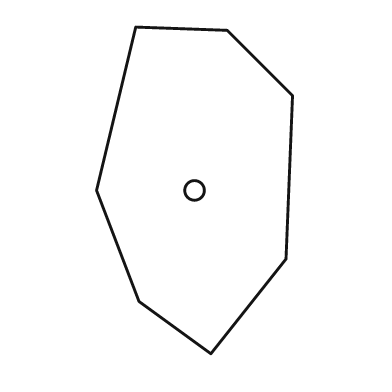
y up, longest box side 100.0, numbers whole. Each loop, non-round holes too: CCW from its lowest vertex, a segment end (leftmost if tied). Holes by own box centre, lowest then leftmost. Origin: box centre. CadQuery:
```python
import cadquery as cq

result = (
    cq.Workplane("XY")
    .moveTo(5.0, -50.0)
    .lineTo(28.0, -21.0)
    .lineTo(30.0, 29.0)
    .lineTo(10.0, 49.0)
    .lineTo(-18.0, 50.0)
    .lineTo(-30.0, 0.0)
    .lineTo(-17.0, -34.0)
    .close()
    .moveTo(0.0, 0.0)
    .circle(3.0)
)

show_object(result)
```